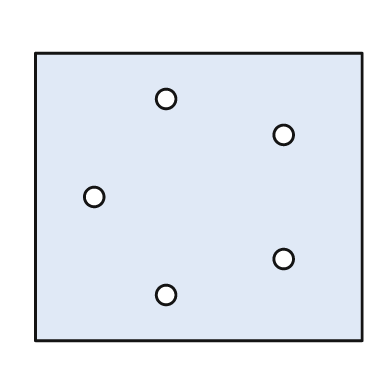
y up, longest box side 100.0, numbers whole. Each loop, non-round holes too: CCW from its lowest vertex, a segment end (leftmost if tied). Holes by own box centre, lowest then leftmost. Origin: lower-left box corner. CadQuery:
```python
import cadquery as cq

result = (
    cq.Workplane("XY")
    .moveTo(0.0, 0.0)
    .lineTo(100.0, 0.0)
    .lineTo(100.0, 88.0)
    .lineTo(0.0, 88.0)
    .close()
    .moveTo(40.0, 14.0)
    .circle(3.0)
    .moveTo(76.0, 25.0)
    .circle(3.0)
    .moveTo(18.0, 44.0)
    .circle(3.0)
    .moveTo(76.0, 63.0)
    .circle(3.0)
    .moveTo(40.0, 74.0)
    .circle(3.0)
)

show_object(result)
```